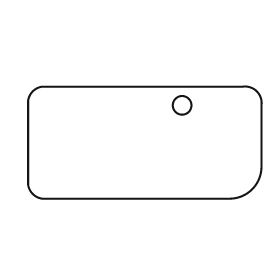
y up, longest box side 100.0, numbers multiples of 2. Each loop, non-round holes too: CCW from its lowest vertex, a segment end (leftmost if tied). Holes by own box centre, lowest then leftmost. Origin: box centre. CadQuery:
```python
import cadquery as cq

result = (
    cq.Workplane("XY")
    .moveTo(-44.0, -24.0)
    .lineTo(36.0, -24.0)
    .threePointArc((46.0, -20.0), (50.0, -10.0))
    .lineTo(50.0, 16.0)
    .threePointArc((48.0, 22.0), (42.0, 24.0))
    .lineTo(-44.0, 24.0)
    .threePointArc((-48.0, 22.0), (-50.0, 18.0))
    .lineTo(-50.0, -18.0)
    .threePointArc((-48.0, -22.0), (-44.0, -24.0))
    .close()
    .moveTo(16.0, 16.0)
    .circle(4.0)
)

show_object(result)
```